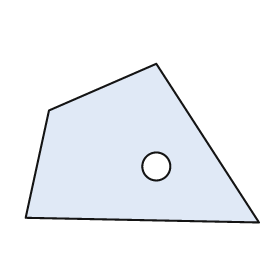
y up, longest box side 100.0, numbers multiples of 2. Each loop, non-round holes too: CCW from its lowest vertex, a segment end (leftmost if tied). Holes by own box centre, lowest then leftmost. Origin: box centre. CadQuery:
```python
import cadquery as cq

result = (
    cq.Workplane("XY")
    .moveTo(50.0, -34.0)
    .lineTo(6.0, 34.0)
    .lineTo(-40.0, 14.0)
    .lineTo(-50.0, -32.0)
    .close()
    .moveTo(6.0, -10.0)
    .circle(6.0)
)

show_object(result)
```